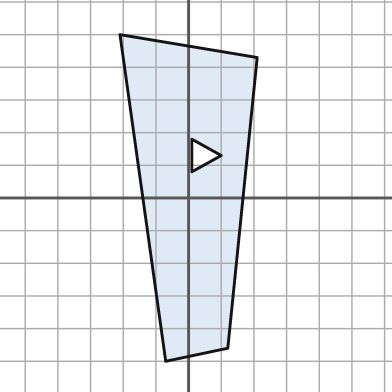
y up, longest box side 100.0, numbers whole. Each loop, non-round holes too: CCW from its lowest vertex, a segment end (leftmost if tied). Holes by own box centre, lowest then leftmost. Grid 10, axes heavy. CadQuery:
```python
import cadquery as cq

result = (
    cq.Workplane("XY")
    .moveTo(-7.0, -50.0)
    .lineTo(12.0, -46.0)
    .lineTo(21.0, 43.0)
    .lineTo(-21.0, 50.0)
    .close()
    .moveTo(1.0, 8.0)
    .lineTo(10.0, 13.0)
    .lineTo(1.0, 18.0)
    .close()
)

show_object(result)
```